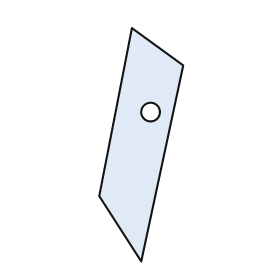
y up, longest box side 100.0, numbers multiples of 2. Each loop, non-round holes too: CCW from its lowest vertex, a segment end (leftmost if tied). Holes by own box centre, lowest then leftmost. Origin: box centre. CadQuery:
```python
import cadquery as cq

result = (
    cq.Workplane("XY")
    .moveTo(0.0, -50.0)
    .lineTo(18.0, 34.0)
    .lineTo(-4.0, 50.0)
    .lineTo(-18.0, -22.0)
    .close()
    .moveTo(4.0, 14.0)
    .circle(4.0)
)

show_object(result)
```